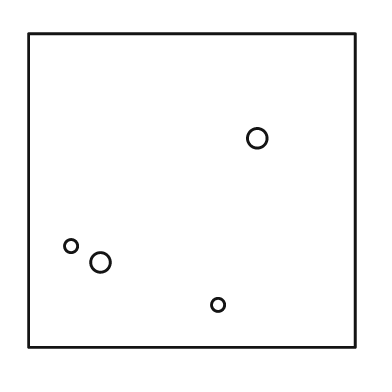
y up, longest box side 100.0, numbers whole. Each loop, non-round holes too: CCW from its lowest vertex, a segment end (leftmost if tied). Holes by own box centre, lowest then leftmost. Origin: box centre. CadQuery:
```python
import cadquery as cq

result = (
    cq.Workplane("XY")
    .moveTo(-50.0, -48.0)
    .lineTo(50.0, -48.0)
    .lineTo(50.0, 48.0)
    .lineTo(-50.0, 48.0)
    .close()
    .moveTo(8.0, -35.0)
    .circle(2.0)
    .moveTo(-28.0, -22.0)
    .circle(3.0)
    .moveTo(-37.0, -17.0)
    .circle(2.0)
    .moveTo(20.0, 16.0)
    .circle(3.0)
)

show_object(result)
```